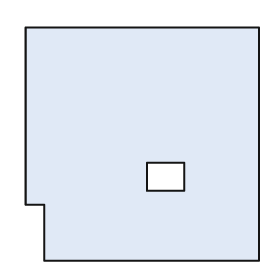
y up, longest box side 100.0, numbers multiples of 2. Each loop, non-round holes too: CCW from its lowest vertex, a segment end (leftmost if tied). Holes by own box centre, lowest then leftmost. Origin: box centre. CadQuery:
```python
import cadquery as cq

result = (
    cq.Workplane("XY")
    .moveTo(-42.0, -50.0)
    .lineTo(50.0, -50.0)
    .lineTo(50.0, 50.0)
    .lineTo(-50.0, 50.0)
    .lineTo(-50.0, -26.0)
    .lineTo(-42.0, -26.0)
    .close()
    .moveTo(2.0, -20.0)
    .lineTo(18.0, -20.0)
    .lineTo(18.0, -8.0)
    .lineTo(2.0, -8.0)
    .close()
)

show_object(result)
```